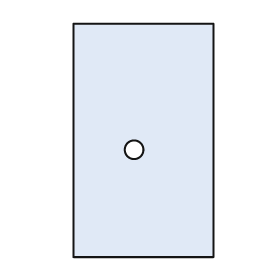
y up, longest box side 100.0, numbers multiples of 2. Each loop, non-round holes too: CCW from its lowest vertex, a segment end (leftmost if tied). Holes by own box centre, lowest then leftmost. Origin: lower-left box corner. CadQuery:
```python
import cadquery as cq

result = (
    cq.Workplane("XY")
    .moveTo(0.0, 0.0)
    .lineTo(60.0, 0.0)
    .lineTo(60.0, 100.0)
    .lineTo(0.0, 100.0)
    .close()
    .moveTo(26.0, 46.0)
    .circle(4.0)
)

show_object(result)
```